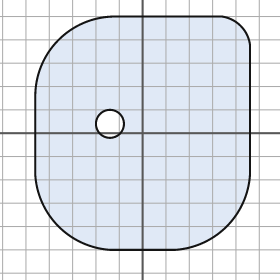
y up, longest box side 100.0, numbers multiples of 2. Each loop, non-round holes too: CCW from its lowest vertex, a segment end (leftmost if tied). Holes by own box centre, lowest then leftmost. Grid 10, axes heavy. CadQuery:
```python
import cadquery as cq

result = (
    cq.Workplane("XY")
    .moveTo(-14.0, -50.0)
    .lineTo(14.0, -50.0)
    .threePointArc((36.0, -40.0), (46.0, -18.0))
    .lineTo(46.0, 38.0)
    .threePointArc((42.0, 46.0), (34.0, 50.0))
    .lineTo(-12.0, 50.0)
    .threePointArc((-36.0, 40.0), (-46.0, 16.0))
    .lineTo(-46.0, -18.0)
    .threePointArc((-36.0, -40.0), (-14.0, -50.0))
    .close()
    .moveTo(-14.0, 4.0)
    .circle(6.0)
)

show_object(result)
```